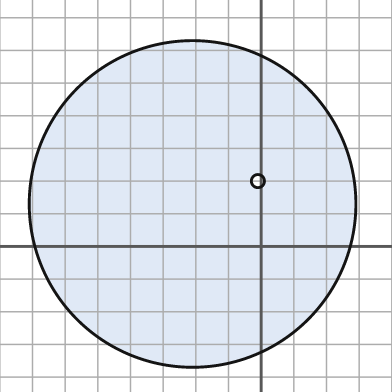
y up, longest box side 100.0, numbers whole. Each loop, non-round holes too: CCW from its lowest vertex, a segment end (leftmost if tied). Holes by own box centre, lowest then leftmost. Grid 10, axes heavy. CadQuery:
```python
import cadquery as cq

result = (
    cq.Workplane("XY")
    .moveTo(-21.0, 13.0)
    .circle(50.0)
    .moveTo(-1.0, 20.0)
    .circle(2.0)
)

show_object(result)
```